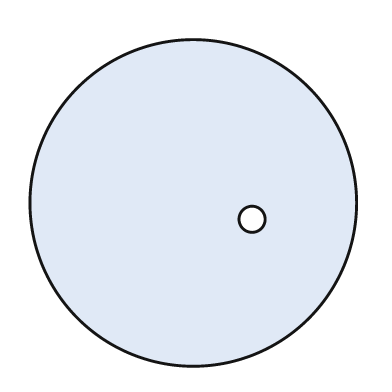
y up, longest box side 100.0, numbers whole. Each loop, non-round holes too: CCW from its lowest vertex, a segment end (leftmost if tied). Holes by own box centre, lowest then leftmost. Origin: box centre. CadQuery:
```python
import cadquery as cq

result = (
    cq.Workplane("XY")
    .moveTo(0.0, 0.0)
    .circle(50.0)
    .moveTo(18.0, -5.0)
    .circle(4.0)
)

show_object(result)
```